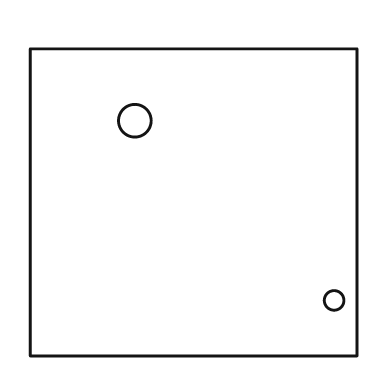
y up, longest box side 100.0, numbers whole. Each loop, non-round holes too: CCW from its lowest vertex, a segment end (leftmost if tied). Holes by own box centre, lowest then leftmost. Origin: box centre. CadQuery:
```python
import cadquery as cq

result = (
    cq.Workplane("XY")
    .moveTo(-50.0, -47.0)
    .lineTo(50.0, -47.0)
    .lineTo(50.0, 47.0)
    .lineTo(-50.0, 47.0)
    .close()
    .moveTo(43.0, -30.0)
    .circle(3.0)
    .moveTo(-18.0, 25.0)
    .circle(5.0)
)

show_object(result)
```